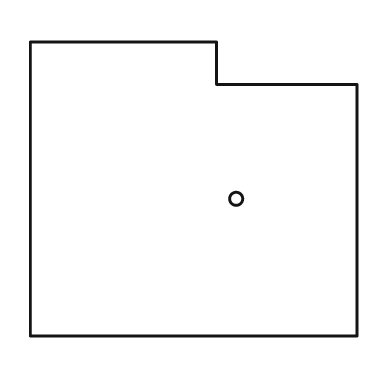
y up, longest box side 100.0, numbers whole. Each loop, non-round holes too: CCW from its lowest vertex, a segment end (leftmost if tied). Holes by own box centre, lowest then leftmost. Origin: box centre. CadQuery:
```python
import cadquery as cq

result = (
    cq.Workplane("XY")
    .moveTo(-50.0, -45.0)
    .lineTo(50.0, -45.0)
    .lineTo(50.0, 32.0)
    .lineTo(7.0, 32.0)
    .lineTo(7.0, 45.0)
    .lineTo(-50.0, 45.0)
    .close()
    .moveTo(13.0, -3.0)
    .circle(2.0)
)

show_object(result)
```